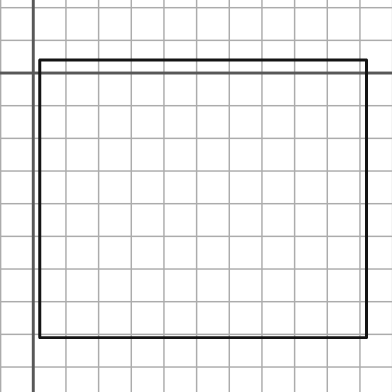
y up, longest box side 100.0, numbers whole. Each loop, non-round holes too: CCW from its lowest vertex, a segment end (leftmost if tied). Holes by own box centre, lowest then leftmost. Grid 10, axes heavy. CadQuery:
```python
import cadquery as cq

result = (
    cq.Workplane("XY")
    .moveTo(2.0, -81.0)
    .lineTo(102.0, -81.0)
    .lineTo(102.0, 4.0)
    .lineTo(2.0, 4.0)
    .close()
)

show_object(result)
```